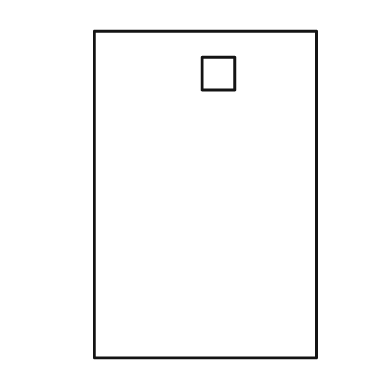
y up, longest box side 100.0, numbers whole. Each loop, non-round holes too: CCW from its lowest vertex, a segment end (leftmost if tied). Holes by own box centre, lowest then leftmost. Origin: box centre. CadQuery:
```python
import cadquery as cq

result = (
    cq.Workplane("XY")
    .moveTo(-34.0, -50.0)
    .lineTo(34.0, -50.0)
    .lineTo(34.0, 50.0)
    .lineTo(-34.0, 50.0)
    .close()
    .moveTo(-1.0, 32.0)
    .lineTo(9.0, 32.0)
    .lineTo(9.0, 42.0)
    .lineTo(-1.0, 42.0)
    .close()
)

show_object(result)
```